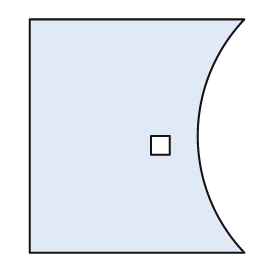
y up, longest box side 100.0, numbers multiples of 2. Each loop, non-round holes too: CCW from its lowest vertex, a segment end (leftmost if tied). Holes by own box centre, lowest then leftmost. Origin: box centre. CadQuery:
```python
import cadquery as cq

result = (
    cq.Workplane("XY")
    .moveTo(-46.0, -50.0)
    .lineTo(46.0, -50.0)
    .threePointArc((26.0, 0.0), (46.0, 50.0))
    .lineTo(-46.0, 50.0)
    .close()
    .moveTo(6.0, -8.0)
    .lineTo(14.0, -8.0)
    .lineTo(14.0, 0.0)
    .lineTo(6.0, 0.0)
    .close()
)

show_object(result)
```